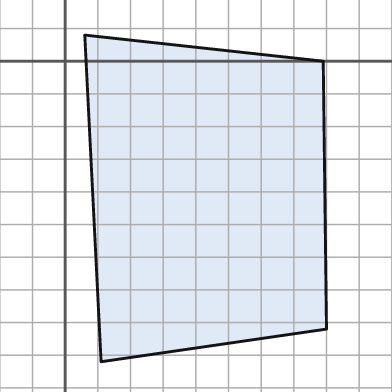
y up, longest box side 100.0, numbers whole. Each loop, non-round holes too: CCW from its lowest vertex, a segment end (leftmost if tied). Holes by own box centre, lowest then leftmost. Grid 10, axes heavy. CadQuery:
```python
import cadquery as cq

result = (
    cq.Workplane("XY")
    .moveTo(11.0, -92.0)
    .lineTo(80.0, -82.0)
    .lineTo(79.0, 0.0)
    .lineTo(6.0, 8.0)
    .close()
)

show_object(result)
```